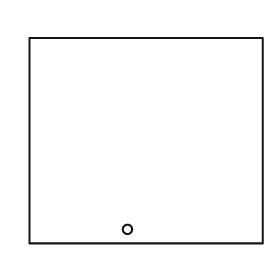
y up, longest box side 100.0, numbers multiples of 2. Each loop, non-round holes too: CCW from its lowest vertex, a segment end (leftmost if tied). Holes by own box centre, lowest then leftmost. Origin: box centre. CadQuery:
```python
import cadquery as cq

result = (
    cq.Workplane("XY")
    .moveTo(-50.0, -44.0)
    .lineTo(50.0, -44.0)
    .lineTo(50.0, 44.0)
    .lineTo(-50.0, 44.0)
    .close()
    .moveTo(-8.0, -38.0)
    .circle(2.0)
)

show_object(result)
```